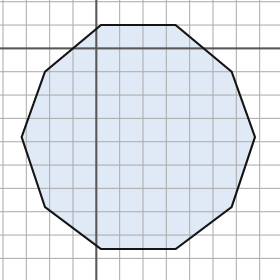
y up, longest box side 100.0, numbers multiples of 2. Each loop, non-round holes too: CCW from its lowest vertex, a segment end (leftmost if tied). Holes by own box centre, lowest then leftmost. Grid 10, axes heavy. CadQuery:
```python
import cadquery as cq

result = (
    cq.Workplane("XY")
    .moveTo(2.0, -86.0)
    .lineTo(34.0, -86.0)
    .lineTo(58.0, -68.0)
    .lineTo(68.0, -38.0)
    .lineTo(58.0, -10.0)
    .lineTo(34.0, 10.0)
    .lineTo(2.0, 10.0)
    .lineTo(-22.0, -10.0)
    .lineTo(-32.0, -38.0)
    .lineTo(-22.0, -68.0)
    .close()
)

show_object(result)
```